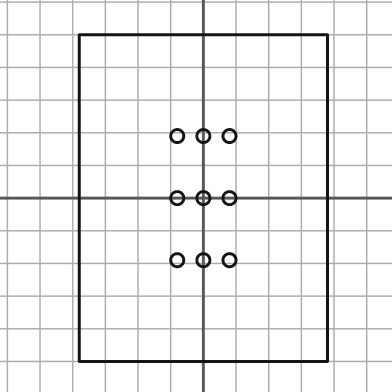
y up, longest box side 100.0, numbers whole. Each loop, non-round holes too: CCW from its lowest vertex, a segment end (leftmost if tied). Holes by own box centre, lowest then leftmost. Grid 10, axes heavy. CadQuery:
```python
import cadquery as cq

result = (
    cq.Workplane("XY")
    .moveTo(-38.0, -50.0)
    .lineTo(38.0, -50.0)
    .lineTo(38.0, 50.0)
    .lineTo(-38.0, 50.0)
    .close()
    .moveTo(-8.0, -19.0)
    .circle(2.0)
    .moveTo(0.0, -19.0)
    .circle(2.0)
    .moveTo(8.0, -19.0)
    .circle(2.0)
    .moveTo(-8.0, 0.0)
    .circle(2.0)
    .moveTo(0.0, 0.0)
    .circle(2.0)
    .moveTo(8.0, 0.0)
    .circle(2.0)
    .moveTo(-8.0, 19.0)
    .circle(2.0)
    .moveTo(0.0, 19.0)
    .circle(2.0)
    .moveTo(8.0, 19.0)
    .circle(2.0)
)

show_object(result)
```